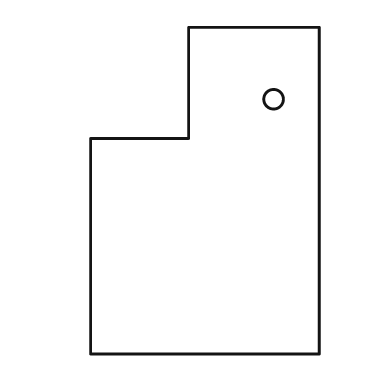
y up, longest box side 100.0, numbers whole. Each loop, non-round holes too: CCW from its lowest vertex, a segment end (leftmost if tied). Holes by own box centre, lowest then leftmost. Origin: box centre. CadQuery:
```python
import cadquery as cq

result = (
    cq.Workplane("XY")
    .moveTo(-35.0, -50.0)
    .lineTo(35.0, -50.0)
    .lineTo(35.0, 50.0)
    .lineTo(-5.0, 50.0)
    .lineTo(-5.0, 16.0)
    .lineTo(-35.0, 16.0)
    .close()
    .moveTo(21.0, 28.0)
    .circle(3.0)
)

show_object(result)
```